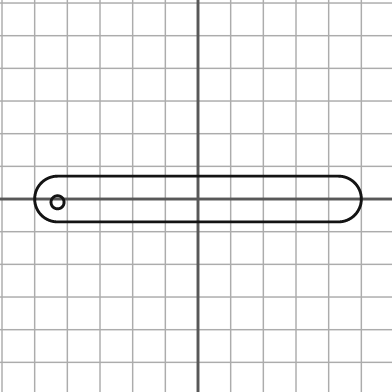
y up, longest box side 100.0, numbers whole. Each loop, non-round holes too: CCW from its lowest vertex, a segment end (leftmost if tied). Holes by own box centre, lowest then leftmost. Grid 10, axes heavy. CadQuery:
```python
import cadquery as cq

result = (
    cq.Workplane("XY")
    .moveTo(-43.0, -7.0)
    .lineTo(43.0, -7.0)
    .threePointArc((50.0, 0.0), (43.0, 7.0))
    .lineTo(-43.0, 7.0)
    .threePointArc((-50.0, 0.0), (-43.0, -7.0))
    .close()
    .moveTo(-43.0, -1.0)
    .circle(2.0)
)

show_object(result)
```